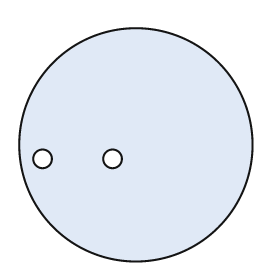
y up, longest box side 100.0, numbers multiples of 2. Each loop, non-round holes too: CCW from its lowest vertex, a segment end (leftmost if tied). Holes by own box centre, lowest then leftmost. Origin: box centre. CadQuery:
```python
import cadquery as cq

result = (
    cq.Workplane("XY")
    .moveTo(0.0, 0.0)
    .circle(50.0)
    .moveTo(-40.0, -6.0)
    .circle(4.0)
    .moveTo(-10.0, -6.0)
    .circle(4.0)
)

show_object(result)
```